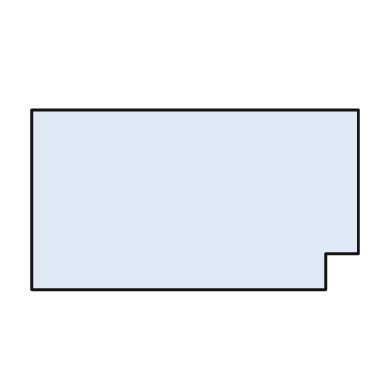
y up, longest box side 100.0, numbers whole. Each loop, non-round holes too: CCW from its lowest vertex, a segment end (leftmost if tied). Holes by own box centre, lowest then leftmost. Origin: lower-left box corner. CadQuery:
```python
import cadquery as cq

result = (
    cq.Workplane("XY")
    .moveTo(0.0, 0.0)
    .lineTo(90.0, 0.0)
    .lineTo(90.0, 11.0)
    .lineTo(100.0, 11.0)
    .lineTo(100.0, 55.0)
    .lineTo(0.0, 55.0)
    .close()
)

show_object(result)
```